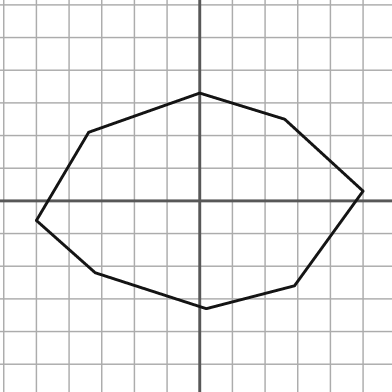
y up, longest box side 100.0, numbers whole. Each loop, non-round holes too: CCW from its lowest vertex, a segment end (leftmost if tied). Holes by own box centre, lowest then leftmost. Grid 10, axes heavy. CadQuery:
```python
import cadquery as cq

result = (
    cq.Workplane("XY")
    .moveTo(2.0, -33.0)
    .lineTo(29.0, -26.0)
    .lineTo(50.0, 3.0)
    .lineTo(26.0, 25.0)
    .lineTo(0.0, 33.0)
    .lineTo(-34.0, 21.0)
    .lineTo(-50.0, -6.0)
    .lineTo(-32.0, -22.0)
    .close()
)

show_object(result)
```